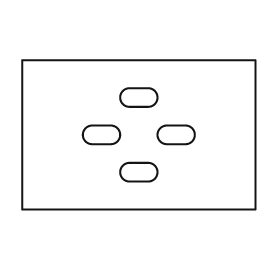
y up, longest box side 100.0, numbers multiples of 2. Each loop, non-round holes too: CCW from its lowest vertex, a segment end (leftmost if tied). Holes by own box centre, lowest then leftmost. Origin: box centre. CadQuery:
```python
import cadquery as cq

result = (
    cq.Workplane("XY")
    .moveTo(-50.0, -32.0)
    .lineTo(50.0, -32.0)
    .lineTo(50.0, 32.0)
    .lineTo(-50.0, 32.0)
    .close()
    .moveTo(-4.0, -20.0)
    .lineTo(4.0, -20.0)
    .threePointArc((8.0, -16.0), (4.0, -12.0))
    .lineTo(-4.0, -12.0)
    .threePointArc((-8.0, -16.0), (-4.0, -20.0))
    .close()
    .moveTo(-20.0, -4.0)
    .lineTo(-12.0, -4.0)
    .threePointArc((-8.0, 0.0), (-12.0, 4.0))
    .lineTo(-20.0, 4.0)
    .threePointArc((-24.0, 0.0), (-20.0, -4.0))
    .close()
    .moveTo(12.0, -4.0)
    .lineTo(20.0, -4.0)
    .threePointArc((24.0, 0.0), (20.0, 4.0))
    .lineTo(12.0, 4.0)
    .threePointArc((8.0, 0.0), (12.0, -4.0))
    .close()
    .moveTo(-4.0, 12.0)
    .lineTo(4.0, 12.0)
    .threePointArc((8.0, 16.0), (4.0, 20.0))
    .lineTo(-4.0, 20.0)
    .threePointArc((-8.0, 16.0), (-4.0, 12.0))
    .close()
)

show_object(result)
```